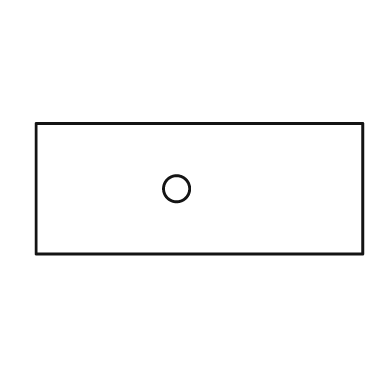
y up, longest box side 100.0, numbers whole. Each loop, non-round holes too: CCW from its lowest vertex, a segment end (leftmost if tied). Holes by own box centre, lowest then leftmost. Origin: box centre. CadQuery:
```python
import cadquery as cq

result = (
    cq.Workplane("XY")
    .moveTo(-50.0, -20.0)
    .lineTo(50.0, -20.0)
    .lineTo(50.0, 20.0)
    .lineTo(-50.0, 20.0)
    .close()
    .moveTo(-7.0, 0.0)
    .circle(4.0)
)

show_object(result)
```